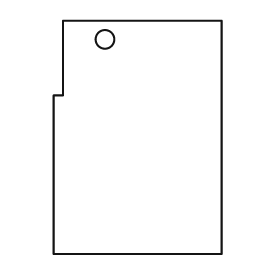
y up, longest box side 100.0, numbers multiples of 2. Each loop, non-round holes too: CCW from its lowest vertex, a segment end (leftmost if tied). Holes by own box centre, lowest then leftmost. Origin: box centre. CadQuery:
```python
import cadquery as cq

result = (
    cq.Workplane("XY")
    .moveTo(-36.0, -50.0)
    .lineTo(36.0, -50.0)
    .lineTo(36.0, 50.0)
    .lineTo(-32.0, 50.0)
    .lineTo(-32.0, 18.0)
    .lineTo(-36.0, 18.0)
    .close()
    .moveTo(-14.0, 42.0)
    .circle(4.0)
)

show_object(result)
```